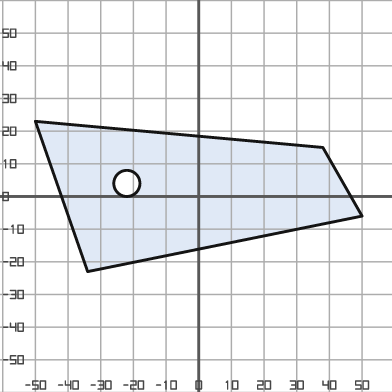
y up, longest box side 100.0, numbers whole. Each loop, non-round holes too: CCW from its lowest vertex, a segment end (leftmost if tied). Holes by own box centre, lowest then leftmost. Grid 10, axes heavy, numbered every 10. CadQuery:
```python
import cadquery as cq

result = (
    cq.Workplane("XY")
    .moveTo(-34.0, -23.0)
    .lineTo(50.0, -6.0)
    .lineTo(38.0, 15.0)
    .lineTo(-50.0, 23.0)
    .close()
    .moveTo(-22.0, 4.0)
    .circle(4.0)
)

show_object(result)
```